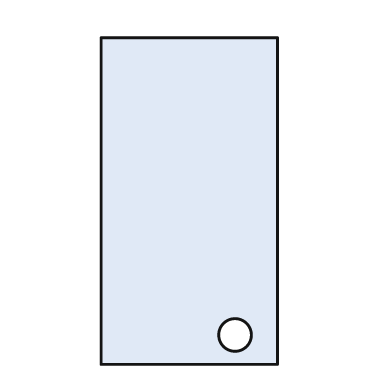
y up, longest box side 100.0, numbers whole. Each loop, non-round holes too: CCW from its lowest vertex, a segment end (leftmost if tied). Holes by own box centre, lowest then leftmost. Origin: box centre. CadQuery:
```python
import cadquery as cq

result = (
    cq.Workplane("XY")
    .moveTo(-27.0, -50.0)
    .lineTo(27.0, -50.0)
    .lineTo(27.0, 50.0)
    .lineTo(-27.0, 50.0)
    .close()
    .moveTo(14.0, -41.0)
    .circle(5.0)
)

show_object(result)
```